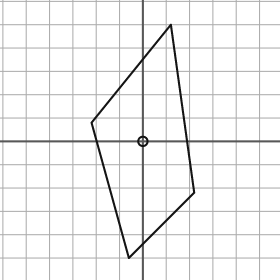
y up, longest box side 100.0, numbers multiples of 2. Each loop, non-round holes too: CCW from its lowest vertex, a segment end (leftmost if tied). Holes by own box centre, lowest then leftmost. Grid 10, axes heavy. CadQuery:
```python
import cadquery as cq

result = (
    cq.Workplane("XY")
    .moveTo(-6.0, -50.0)
    .lineTo(22.0, -22.0)
    .lineTo(12.0, 50.0)
    .lineTo(-22.0, 8.0)
    .close()
    .moveTo(0.0, 0.0)
    .circle(2.0)
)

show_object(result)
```